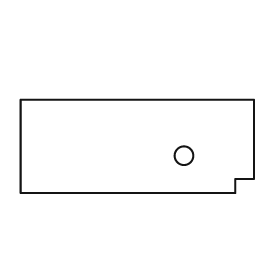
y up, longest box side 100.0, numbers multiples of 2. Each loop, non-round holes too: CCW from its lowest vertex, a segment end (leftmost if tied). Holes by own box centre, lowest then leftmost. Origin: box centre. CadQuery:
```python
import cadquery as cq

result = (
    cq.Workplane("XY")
    .moveTo(-50.0, -20.0)
    .lineTo(42.0, -20.0)
    .lineTo(42.0, -14.0)
    .lineTo(50.0, -14.0)
    .lineTo(50.0, 20.0)
    .lineTo(-50.0, 20.0)
    .close()
    .moveTo(20.0, -4.0)
    .circle(4.0)
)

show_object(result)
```